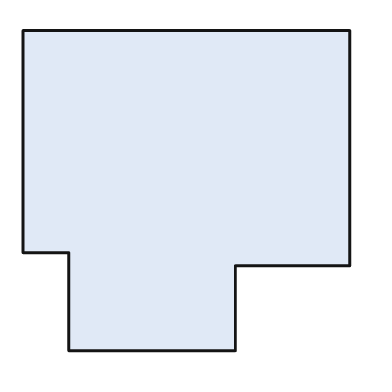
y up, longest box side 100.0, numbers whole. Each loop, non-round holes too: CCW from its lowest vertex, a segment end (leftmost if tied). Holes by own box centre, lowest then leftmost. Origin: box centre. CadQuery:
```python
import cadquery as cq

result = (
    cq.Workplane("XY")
    .moveTo(-36.0, -49.0)
    .lineTo(15.0, -49.0)
    .lineTo(15.0, -23.0)
    .lineTo(50.0, -23.0)
    .lineTo(50.0, 49.0)
    .lineTo(-50.0, 49.0)
    .lineTo(-50.0, -19.0)
    .lineTo(-36.0, -19.0)
    .close()
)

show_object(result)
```